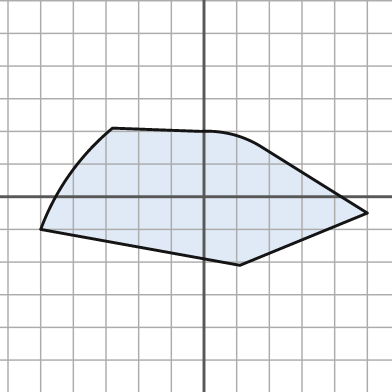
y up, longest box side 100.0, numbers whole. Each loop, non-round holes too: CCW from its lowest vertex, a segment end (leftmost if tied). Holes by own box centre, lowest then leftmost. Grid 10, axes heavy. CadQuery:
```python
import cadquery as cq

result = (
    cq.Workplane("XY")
    .moveTo(11.0, -21.0)
    .lineTo(50.0, -5.0)
    .lineTo(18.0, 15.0)
    .threePointArc((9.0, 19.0), (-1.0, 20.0))
    .lineTo(-28.0, 21.0)
    .threePointArc((-41.0, 7.0), (-50.0, -10.0))
    .close()
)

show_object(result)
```